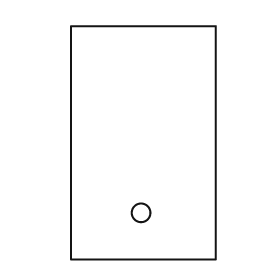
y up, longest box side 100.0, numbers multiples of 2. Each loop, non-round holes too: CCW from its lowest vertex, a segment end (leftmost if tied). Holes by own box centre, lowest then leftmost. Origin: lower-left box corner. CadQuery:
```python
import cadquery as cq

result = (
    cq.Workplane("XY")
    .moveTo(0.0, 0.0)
    .lineTo(62.0, 0.0)
    .lineTo(62.0, 100.0)
    .lineTo(0.0, 100.0)
    .close()
    .moveTo(30.0, 20.0)
    .circle(4.0)
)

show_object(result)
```